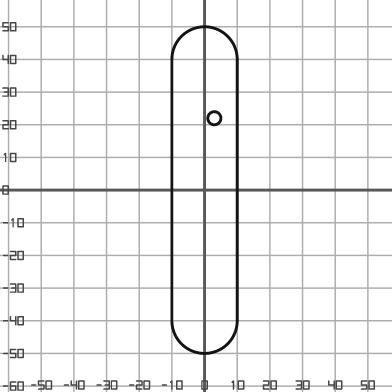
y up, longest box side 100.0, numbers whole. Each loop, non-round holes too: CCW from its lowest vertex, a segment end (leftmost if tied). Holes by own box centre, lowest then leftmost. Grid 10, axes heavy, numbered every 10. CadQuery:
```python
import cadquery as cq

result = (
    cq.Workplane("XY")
    .moveTo(-10.0, -40.0)
    .threePointArc((0.0, -50.0), (10.0, -40.0))
    .lineTo(10.0, 40.0)
    .threePointArc((0.0, 50.0), (-10.0, 40.0))
    .close()
    .moveTo(3.0, 22.0)
    .circle(2.0)
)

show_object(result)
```